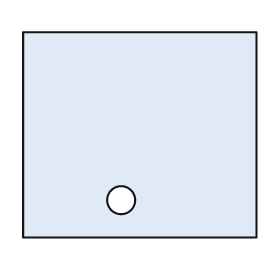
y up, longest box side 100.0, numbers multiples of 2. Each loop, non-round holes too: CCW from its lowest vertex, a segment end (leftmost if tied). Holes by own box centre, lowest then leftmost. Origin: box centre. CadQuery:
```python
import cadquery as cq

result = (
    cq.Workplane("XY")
    .moveTo(-50.0, -44.0)
    .lineTo(50.0, -44.0)
    .lineTo(50.0, 44.0)
    .lineTo(-50.0, 44.0)
    .close()
    .moveTo(-8.0, -28.0)
    .circle(6.0)
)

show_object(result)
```